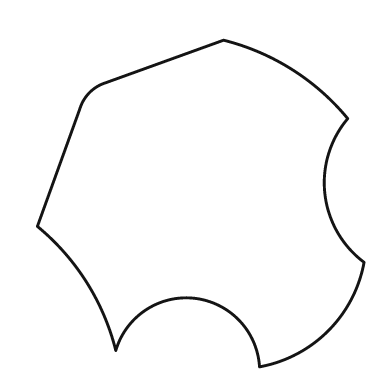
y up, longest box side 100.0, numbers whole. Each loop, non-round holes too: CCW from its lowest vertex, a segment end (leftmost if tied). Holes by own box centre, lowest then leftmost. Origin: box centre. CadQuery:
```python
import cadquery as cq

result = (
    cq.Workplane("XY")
    .moveTo(18.0, -50.0)
    .threePointArc((39.0, -39.0), (50.0, -18.0))
    .threePointArc((38.0, 3.0), (45.0, 26.0))
    .threePointArc((28.0, 41.0), (7.0, 50.0))
    .lineTo(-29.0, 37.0)
    .threePointArc((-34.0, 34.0), (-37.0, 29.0))
    .lineTo(-50.0, -7.0)
    .threePointArc((-35.0, -24.0), (-26.0, -45.0))
    .threePointArc((-2.0, -29.0), (18.0, -50.0))
    .close()
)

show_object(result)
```